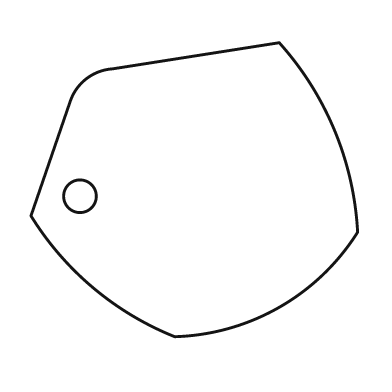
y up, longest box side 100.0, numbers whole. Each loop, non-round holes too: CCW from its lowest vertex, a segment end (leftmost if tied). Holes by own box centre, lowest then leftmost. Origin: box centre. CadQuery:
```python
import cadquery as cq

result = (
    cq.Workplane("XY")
    .moveTo(-6.0, -45.0)
    .threePointArc((26.0, -36.0), (50.0, -13.0))
    .threePointArc((43.0, 18.0), (26.0, 45.0))
    .lineTo(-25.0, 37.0)
    .threePointArc((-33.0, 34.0), (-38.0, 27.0))
    .lineTo(-50.0, -8.0)
    .threePointArc((-31.0, -30.0), (-6.0, -45.0))
    .close()
    .moveTo(-35.0, -2.0)
    .circle(5.0)
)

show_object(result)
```